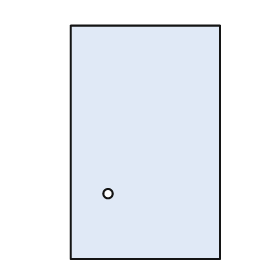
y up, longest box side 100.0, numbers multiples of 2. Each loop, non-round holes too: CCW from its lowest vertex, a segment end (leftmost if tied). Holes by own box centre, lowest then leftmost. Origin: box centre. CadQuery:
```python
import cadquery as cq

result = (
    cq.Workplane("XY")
    .moveTo(-32.0, -50.0)
    .lineTo(32.0, -50.0)
    .lineTo(32.0, 50.0)
    .lineTo(-32.0, 50.0)
    .close()
    .moveTo(-16.0, -22.0)
    .circle(2.0)
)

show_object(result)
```